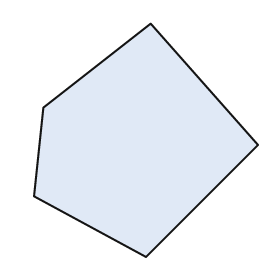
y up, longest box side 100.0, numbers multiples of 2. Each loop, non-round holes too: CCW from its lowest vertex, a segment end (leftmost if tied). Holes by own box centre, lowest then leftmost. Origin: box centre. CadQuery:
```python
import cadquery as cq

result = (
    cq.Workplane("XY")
    .moveTo(0.0, -50.0)
    .lineTo(48.0, -2.0)
    .lineTo(2.0, 50.0)
    .lineTo(-44.0, 14.0)
    .lineTo(-48.0, -24.0)
    .close()
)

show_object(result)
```